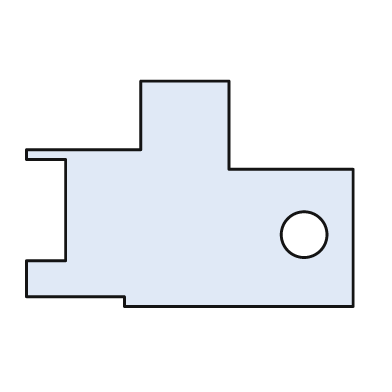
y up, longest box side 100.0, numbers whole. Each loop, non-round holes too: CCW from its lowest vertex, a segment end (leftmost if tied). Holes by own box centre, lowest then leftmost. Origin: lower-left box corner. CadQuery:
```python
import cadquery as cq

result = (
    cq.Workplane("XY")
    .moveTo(30.0, 0.0)
    .lineTo(100.0, 0.0)
    .lineTo(100.0, 42.0)
    .lineTo(62.0, 42.0)
    .lineTo(62.0, 69.0)
    .lineTo(35.0, 69.0)
    .lineTo(35.0, 48.0)
    .lineTo(0.0, 48.0)
    .lineTo(0.0, 45.0)
    .lineTo(12.0, 45.0)
    .lineTo(12.0, 14.0)
    .lineTo(0.0, 14.0)
    .lineTo(0.0, 3.0)
    .lineTo(30.0, 3.0)
    .close()
    .moveTo(85.0, 22.0)
    .circle(7.0)
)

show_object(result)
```